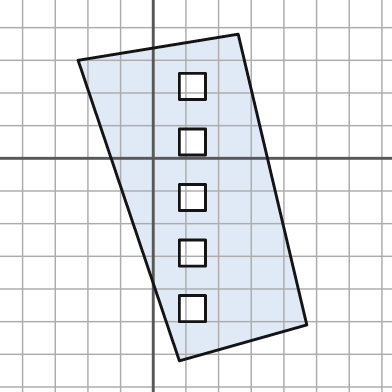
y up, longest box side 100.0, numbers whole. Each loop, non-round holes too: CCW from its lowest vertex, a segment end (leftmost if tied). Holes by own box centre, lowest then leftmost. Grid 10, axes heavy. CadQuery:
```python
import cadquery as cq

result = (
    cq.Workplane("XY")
    .moveTo(8.0, -62.0)
    .lineTo(47.0, -51.0)
    .lineTo(26.0, 38.0)
    .lineTo(-23.0, 30.0)
    .close()
    .moveTo(8.0, -50.0)
    .lineTo(16.0, -50.0)
    .lineTo(16.0, -42.0)
    .lineTo(8.0, -42.0)
    .close()
    .moveTo(8.0, -33.0)
    .lineTo(16.0, -33.0)
    .lineTo(16.0, -25.0)
    .lineTo(8.0, -25.0)
    .close()
    .moveTo(8.0, -16.0)
    .lineTo(16.0, -16.0)
    .lineTo(16.0, -8.0)
    .lineTo(8.0, -8.0)
    .close()
    .moveTo(8.0, 1.0)
    .lineTo(16.0, 1.0)
    .lineTo(16.0, 9.0)
    .lineTo(8.0, 9.0)
    .close()
    .moveTo(8.0, 18.0)
    .lineTo(16.0, 18.0)
    .lineTo(16.0, 26.0)
    .lineTo(8.0, 26.0)
    .close()
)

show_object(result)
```